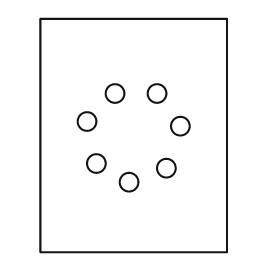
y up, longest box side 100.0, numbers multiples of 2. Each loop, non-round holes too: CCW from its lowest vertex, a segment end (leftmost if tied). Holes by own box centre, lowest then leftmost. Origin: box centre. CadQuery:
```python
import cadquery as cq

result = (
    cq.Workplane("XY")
    .moveTo(-40.0, -50.0)
    .lineTo(40.0, -50.0)
    .lineTo(40.0, 50.0)
    .lineTo(-40.0, 50.0)
    .close()
    .moveTo(-2.0, -20.0)
    .circle(4.0)
    .moveTo(14.0, -14.0)
    .circle(4.0)
    .moveTo(-16.0, -12.0)
    .circle(4.0)
    .moveTo(20.0, 4.0)
    .circle(4.0)
    .moveTo(-20.0, 6.0)
    .circle(4.0)
    .moveTo(-8.0, 18.0)
    .circle(4.0)
    .moveTo(10.0, 18.0)
    .circle(4.0)
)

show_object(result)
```